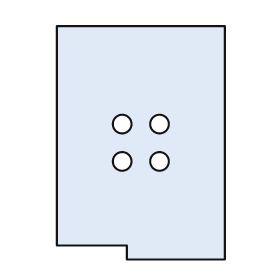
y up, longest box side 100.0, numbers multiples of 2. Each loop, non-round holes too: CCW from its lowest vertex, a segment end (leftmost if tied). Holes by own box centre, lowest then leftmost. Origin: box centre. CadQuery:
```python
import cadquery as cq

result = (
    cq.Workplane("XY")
    .moveTo(-6.0, -50.0)
    .lineTo(36.0, -50.0)
    .lineTo(36.0, 50.0)
    .lineTo(-36.0, 50.0)
    .lineTo(-36.0, -44.0)
    .lineTo(-6.0, -44.0)
    .close()
    .moveTo(-8.0, -8.0)
    .circle(4.0)
    .moveTo(8.0, -8.0)
    .circle(4.0)
    .moveTo(-8.0, 8.0)
    .circle(4.0)
    .moveTo(8.0, 8.0)
    .circle(4.0)
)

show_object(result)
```